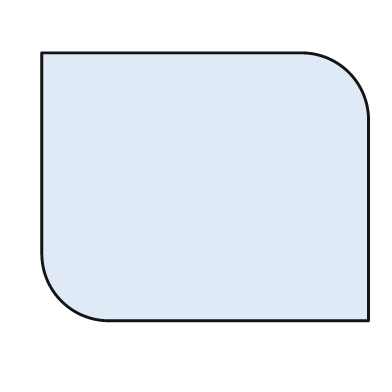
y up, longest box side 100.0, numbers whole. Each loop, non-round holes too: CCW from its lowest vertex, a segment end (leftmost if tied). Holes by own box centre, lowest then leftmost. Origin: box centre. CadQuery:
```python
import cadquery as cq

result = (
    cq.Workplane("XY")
    .moveTo(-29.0, -41.0)
    .lineTo(50.0, -41.0)
    .lineTo(50.0, 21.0)
    .threePointArc((44.0, 35.0), (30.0, 41.0))
    .lineTo(-50.0, 41.0)
    .lineTo(-50.0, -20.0)
    .threePointArc((-44.0, -35.0), (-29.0, -41.0))
    .close()
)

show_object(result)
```